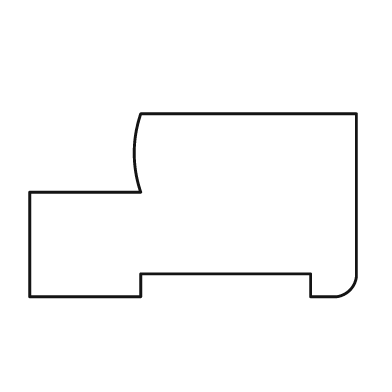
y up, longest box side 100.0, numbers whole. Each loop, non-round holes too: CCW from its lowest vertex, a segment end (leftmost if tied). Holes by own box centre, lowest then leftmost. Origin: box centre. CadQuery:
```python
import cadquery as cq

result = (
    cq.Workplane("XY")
    .moveTo(-50.0, -28.0)
    .lineTo(-16.0, -28.0)
    .lineTo(-16.0, -21.0)
    .lineTo(36.0, -21.0)
    .lineTo(36.0, -28.0)
    .lineTo(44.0, -28.0)
    .threePointArc((48.0, -26.0), (50.0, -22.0))
    .lineTo(50.0, 28.0)
    .lineTo(-16.0, 28.0)
    .threePointArc((-18.0, 16.0), (-16.0, 4.0))
    .lineTo(-50.0, 4.0)
    .close()
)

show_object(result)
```